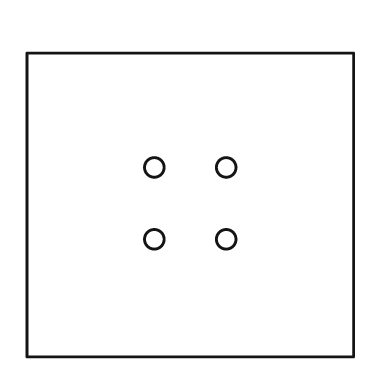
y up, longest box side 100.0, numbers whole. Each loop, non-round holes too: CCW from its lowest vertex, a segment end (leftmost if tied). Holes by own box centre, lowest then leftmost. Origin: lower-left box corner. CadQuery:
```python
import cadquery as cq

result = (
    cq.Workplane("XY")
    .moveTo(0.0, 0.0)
    .lineTo(100.0, 0.0)
    .lineTo(100.0, 93.0)
    .lineTo(0.0, 93.0)
    .close()
    .moveTo(39.0, 36.0)
    .circle(3.0)
    .moveTo(61.0, 36.0)
    .circle(3.0)
    .moveTo(39.0, 58.0)
    .circle(3.0)
    .moveTo(61.0, 58.0)
    .circle(3.0)
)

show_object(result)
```